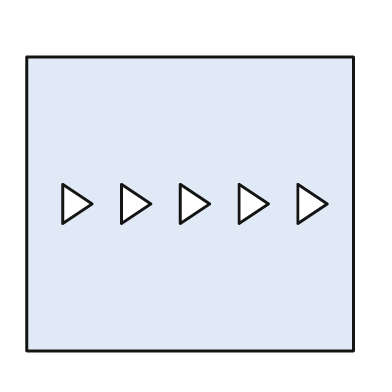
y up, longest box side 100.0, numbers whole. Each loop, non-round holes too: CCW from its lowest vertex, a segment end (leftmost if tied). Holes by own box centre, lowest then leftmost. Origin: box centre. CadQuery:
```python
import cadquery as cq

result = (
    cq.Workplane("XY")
    .moveTo(-50.0, -45.0)
    .lineTo(50.0, -45.0)
    .lineTo(50.0, 45.0)
    .lineTo(-50.0, 45.0)
    .close()
    .moveTo(-39.0, -6.0)
    .lineTo(-30.0, 0.0)
    .lineTo(-39.0, 6.0)
    .close()
    .moveTo(-21.0, -6.0)
    .lineTo(-12.0, 0.0)
    .lineTo(-21.0, 6.0)
    .close()
    .moveTo(-3.0, -6.0)
    .lineTo(6.0, 0.0)
    .lineTo(-3.0, 6.0)
    .close()
    .moveTo(15.0, -6.0)
    .lineTo(24.0, 0.0)
    .lineTo(15.0, 6.0)
    .close()
    .moveTo(33.0, -6.0)
    .lineTo(42.0, 0.0)
    .lineTo(33.0, 6.0)
    .close()
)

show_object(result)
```